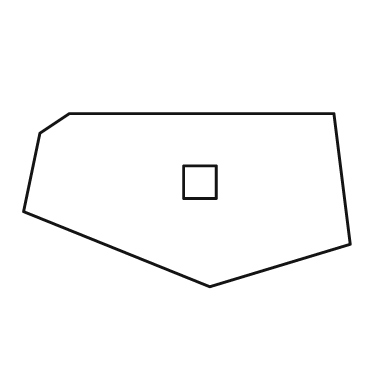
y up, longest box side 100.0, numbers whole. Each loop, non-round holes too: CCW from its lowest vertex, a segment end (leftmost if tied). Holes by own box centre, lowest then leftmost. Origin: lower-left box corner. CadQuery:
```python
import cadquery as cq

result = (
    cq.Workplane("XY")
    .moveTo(57.0, 0.0)
    .lineTo(100.0, 13.0)
    .lineTo(95.0, 53.0)
    .lineTo(14.0, 53.0)
    .lineTo(5.0, 47.0)
    .lineTo(0.0, 23.0)
    .close()
    .moveTo(49.0, 27.0)
    .lineTo(59.0, 27.0)
    .lineTo(59.0, 37.0)
    .lineTo(49.0, 37.0)
    .close()
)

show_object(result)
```